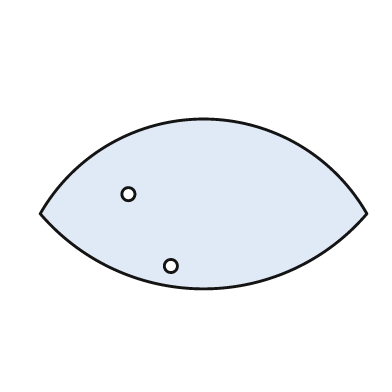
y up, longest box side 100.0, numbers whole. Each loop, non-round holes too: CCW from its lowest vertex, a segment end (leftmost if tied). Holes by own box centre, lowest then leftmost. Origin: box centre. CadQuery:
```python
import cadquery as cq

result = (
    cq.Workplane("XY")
    .moveTo(-50.0, -3.0)
    .threePointArc((0.0, -26.0), (50.0, -3.0))
    .threePointArc((0.0, 26.0), (-50.0, -3.0))
    .close()
    .moveTo(-10.0, -19.0)
    .circle(2.0)
    .moveTo(-23.0, 3.0)
    .circle(2.0)
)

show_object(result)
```